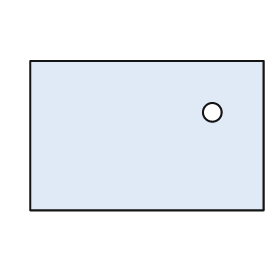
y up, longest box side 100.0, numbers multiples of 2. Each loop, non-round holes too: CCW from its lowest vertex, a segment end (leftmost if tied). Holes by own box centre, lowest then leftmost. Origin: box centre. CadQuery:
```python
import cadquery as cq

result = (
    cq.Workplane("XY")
    .moveTo(-50.0, -32.0)
    .lineTo(50.0, -32.0)
    .lineTo(50.0, 32.0)
    .lineTo(-50.0, 32.0)
    .close()
    .moveTo(28.0, 10.0)
    .circle(4.0)
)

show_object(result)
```